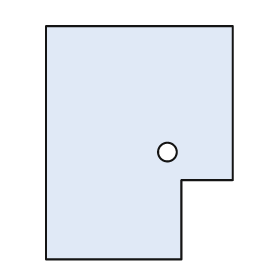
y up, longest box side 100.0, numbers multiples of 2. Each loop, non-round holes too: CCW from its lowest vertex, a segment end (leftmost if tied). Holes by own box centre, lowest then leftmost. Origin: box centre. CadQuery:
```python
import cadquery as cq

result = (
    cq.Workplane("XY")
    .moveTo(-40.0, -50.0)
    .lineTo(18.0, -50.0)
    .lineTo(18.0, -16.0)
    .lineTo(40.0, -16.0)
    .lineTo(40.0, 50.0)
    .lineTo(-40.0, 50.0)
    .close()
    .moveTo(12.0, -4.0)
    .circle(4.0)
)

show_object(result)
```